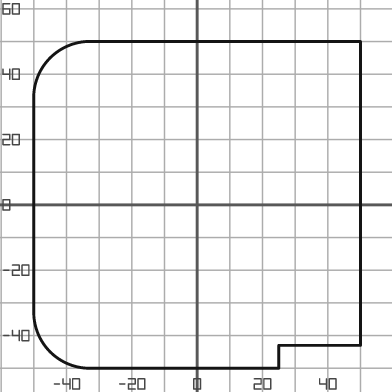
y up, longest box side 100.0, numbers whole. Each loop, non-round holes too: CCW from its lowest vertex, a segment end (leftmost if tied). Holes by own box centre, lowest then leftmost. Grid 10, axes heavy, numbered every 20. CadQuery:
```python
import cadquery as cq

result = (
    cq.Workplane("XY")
    .moveTo(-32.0, -50.0)
    .lineTo(25.0, -50.0)
    .lineTo(25.0, -43.0)
    .lineTo(50.0, -43.0)
    .lineTo(50.0, 50.0)
    .lineTo(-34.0, 50.0)
    .threePointArc((-45.0, 45.0), (-50.0, 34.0))
    .lineTo(-50.0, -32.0)
    .threePointArc((-45.0, -45.0), (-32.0, -50.0))
    .close()
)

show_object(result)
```